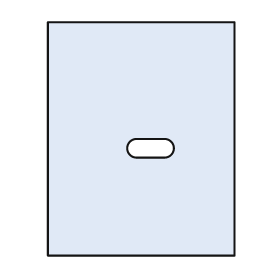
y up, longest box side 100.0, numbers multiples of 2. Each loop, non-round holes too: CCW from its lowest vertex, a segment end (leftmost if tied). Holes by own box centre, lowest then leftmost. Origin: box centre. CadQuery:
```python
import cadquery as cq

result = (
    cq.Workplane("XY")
    .moveTo(-40.0, -50.0)
    .lineTo(40.0, -50.0)
    .lineTo(40.0, 50.0)
    .lineTo(-40.0, 50.0)
    .close()
    .moveTo(-2.0, -8.0)
    .lineTo(10.0, -8.0)
    .threePointArc((14.0, -4.0), (10.0, 0.0))
    .lineTo(-2.0, 0.0)
    .threePointArc((-6.0, -4.0), (-2.0, -8.0))
    .close()
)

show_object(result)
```